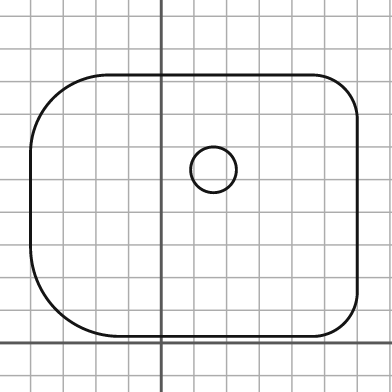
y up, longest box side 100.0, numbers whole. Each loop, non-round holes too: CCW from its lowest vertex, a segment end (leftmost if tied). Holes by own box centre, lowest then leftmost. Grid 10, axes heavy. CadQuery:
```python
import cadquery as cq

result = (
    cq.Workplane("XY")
    .moveTo(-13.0, 2.0)
    .lineTo(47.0, 2.0)
    .threePointArc((56.0, 6.0), (60.0, 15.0))
    .lineTo(60.0, 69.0)
    .threePointArc((56.0, 78.0), (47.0, 82.0))
    .lineTo(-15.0, 82.0)
    .threePointArc((-33.0, 75.0), (-40.0, 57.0))
    .lineTo(-40.0, 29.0)
    .threePointArc((-32.0, 10.0), (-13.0, 2.0))
    .close()
    .moveTo(16.0, 53.0)
    .circle(7.0)
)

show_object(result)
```